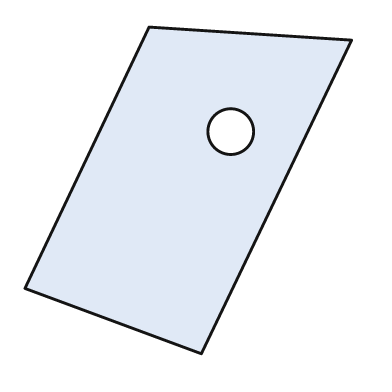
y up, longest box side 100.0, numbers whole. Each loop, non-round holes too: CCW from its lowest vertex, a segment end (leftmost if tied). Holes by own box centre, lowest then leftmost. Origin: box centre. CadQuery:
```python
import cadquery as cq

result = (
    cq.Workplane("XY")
    .moveTo(4.0, -50.0)
    .lineTo(50.0, 46.0)
    .lineTo(-12.0, 50.0)
    .lineTo(-50.0, -30.0)
    .close()
    .moveTo(13.0, 18.0)
    .circle(7.0)
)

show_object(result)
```